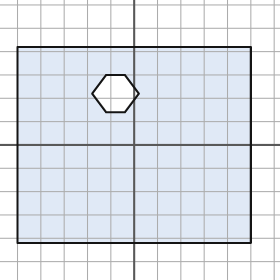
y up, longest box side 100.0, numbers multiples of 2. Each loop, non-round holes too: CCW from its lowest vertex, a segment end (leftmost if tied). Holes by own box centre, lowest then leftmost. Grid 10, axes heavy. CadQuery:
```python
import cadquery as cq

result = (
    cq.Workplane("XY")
    .moveTo(-50.0, -42.0)
    .lineTo(50.0, -42.0)
    .lineTo(50.0, 42.0)
    .lineTo(-50.0, 42.0)
    .close()
    .moveTo(-12.0, 14.0)
    .lineTo(-4.0, 14.0)
    .lineTo(2.0, 22.0)
    .lineTo(-4.0, 30.0)
    .lineTo(-12.0, 30.0)
    .lineTo(-18.0, 22.0)
    .close()
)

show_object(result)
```